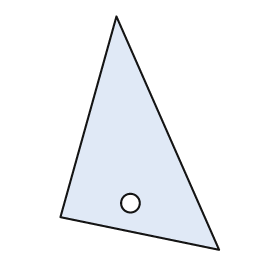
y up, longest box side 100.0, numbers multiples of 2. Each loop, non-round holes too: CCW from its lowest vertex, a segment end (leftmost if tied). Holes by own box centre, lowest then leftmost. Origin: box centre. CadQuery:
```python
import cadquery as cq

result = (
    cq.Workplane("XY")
    .moveTo(34.0, -50.0)
    .lineTo(-10.0, 50.0)
    .lineTo(-34.0, -36.0)
    .close()
    .moveTo(-4.0, -30.0)
    .circle(4.0)
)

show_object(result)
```